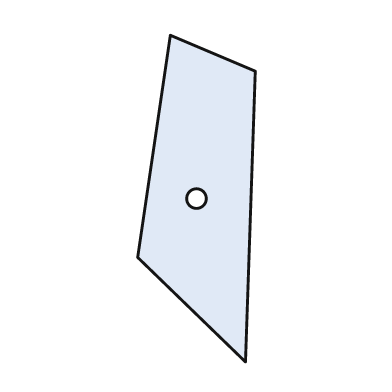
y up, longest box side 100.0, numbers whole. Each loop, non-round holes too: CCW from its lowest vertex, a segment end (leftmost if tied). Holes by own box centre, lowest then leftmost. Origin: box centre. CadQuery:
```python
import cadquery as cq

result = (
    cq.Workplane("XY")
    .moveTo(15.0, -50.0)
    .lineTo(18.0, 39.0)
    .lineTo(-8.0, 50.0)
    .lineTo(-18.0, -18.0)
    .close()
    .moveTo(0.0, 0.0)
    .circle(3.0)
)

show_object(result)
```